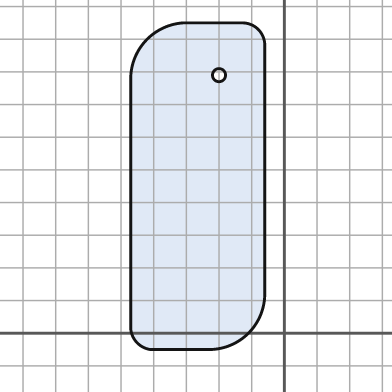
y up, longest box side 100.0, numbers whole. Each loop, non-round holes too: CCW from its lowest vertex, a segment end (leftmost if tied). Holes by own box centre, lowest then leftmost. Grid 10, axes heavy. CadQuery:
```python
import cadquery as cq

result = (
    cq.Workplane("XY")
    .moveTo(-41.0, -5.0)
    .lineTo(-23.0, -5.0)
    .threePointArc((-11.0, 0.0), (-6.0, 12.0))
    .lineTo(-6.0, 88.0)
    .threePointArc((-8.0, 93.0), (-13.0, 95.0))
    .lineTo(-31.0, 95.0)
    .threePointArc((-42.0, 90.0), (-47.0, 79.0))
    .lineTo(-47.0, 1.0)
    .threePointArc((-45.0, -3.0), (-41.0, -5.0))
    .close()
    .moveTo(-20.0, 79.0)
    .circle(2.0)
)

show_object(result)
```